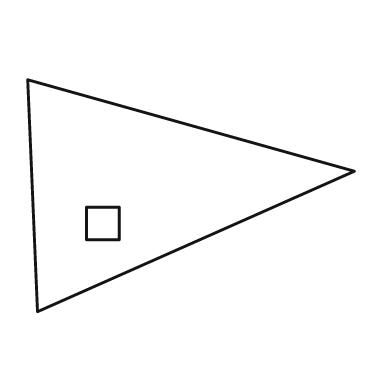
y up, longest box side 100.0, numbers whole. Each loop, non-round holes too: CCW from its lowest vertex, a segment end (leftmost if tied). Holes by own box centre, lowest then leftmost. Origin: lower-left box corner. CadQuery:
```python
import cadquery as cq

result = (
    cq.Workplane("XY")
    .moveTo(3.0, 0.0)
    .lineTo(100.0, 43.0)
    .lineTo(0.0, 71.0)
    .close()
    .moveTo(18.0, 22.0)
    .lineTo(28.0, 22.0)
    .lineTo(28.0, 32.0)
    .lineTo(18.0, 32.0)
    .close()
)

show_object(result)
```